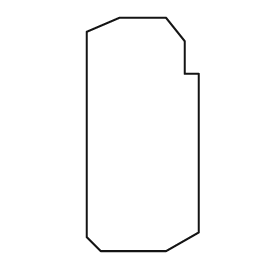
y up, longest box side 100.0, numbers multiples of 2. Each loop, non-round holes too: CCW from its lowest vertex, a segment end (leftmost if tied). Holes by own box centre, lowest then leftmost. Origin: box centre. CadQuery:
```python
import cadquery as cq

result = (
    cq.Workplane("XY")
    .moveTo(-18.0, -50.0)
    .lineTo(10.0, -50.0)
    .lineTo(24.0, -42.0)
    .lineTo(24.0, 26.0)
    .lineTo(18.0, 26.0)
    .lineTo(18.0, 40.0)
    .lineTo(10.0, 50.0)
    .lineTo(-10.0, 50.0)
    .lineTo(-24.0, 44.0)
    .lineTo(-24.0, -44.0)
    .close()
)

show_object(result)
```